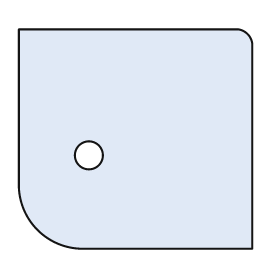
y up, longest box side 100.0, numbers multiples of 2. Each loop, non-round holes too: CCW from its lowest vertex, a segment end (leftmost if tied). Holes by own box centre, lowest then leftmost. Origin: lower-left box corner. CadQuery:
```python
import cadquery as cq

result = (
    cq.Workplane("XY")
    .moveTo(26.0, 0.0)
    .lineTo(100.0, 0.0)
    .lineTo(100.0, 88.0)
    .threePointArc((98.0, 92.0), (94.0, 94.0))
    .lineTo(0.0, 94.0)
    .lineTo(0.0, 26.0)
    .threePointArc((8.0, 8.0), (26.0, 0.0))
    .close()
    .moveTo(30.0, 40.0)
    .circle(6.0)
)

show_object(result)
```